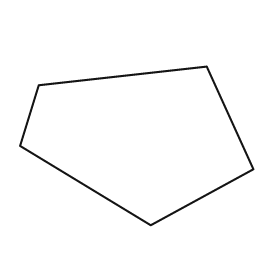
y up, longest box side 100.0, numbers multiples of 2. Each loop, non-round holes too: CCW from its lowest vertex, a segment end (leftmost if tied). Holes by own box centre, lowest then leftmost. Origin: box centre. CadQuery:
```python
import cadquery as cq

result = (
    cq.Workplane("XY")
    .moveTo(6.0, -34.0)
    .lineTo(50.0, -10.0)
    .lineTo(30.0, 34.0)
    .lineTo(-42.0, 26.0)
    .lineTo(-50.0, 0.0)
    .close()
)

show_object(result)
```